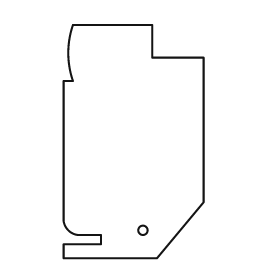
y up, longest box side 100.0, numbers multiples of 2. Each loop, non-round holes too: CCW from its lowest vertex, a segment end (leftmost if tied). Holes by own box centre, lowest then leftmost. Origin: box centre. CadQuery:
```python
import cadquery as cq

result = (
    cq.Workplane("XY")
    .moveTo(-30.0, -50.0)
    .lineTo(10.0, -50.0)
    .lineTo(30.0, -26.0)
    .lineTo(30.0, 36.0)
    .lineTo(8.0, 36.0)
    .lineTo(8.0, 50.0)
    .lineTo(-26.0, 50.0)
    .threePointArc((-28.0, 38.0), (-26.0, 26.0))
    .lineTo(-30.0, 26.0)
    .lineTo(-30.0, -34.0)
    .threePointArc((-28.0, -38.0), (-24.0, -40.0))
    .lineTo(-14.0, -40.0)
    .lineTo(-14.0, -44.0)
    .lineTo(-30.0, -44.0)
    .close()
    .moveTo(4.0, -38.0)
    .circle(2.0)
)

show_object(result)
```